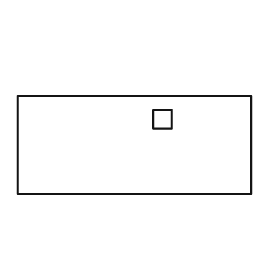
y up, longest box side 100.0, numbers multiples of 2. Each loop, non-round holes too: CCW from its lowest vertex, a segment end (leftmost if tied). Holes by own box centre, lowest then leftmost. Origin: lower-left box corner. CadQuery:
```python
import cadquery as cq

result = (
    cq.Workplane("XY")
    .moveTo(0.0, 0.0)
    .lineTo(100.0, 0.0)
    .lineTo(100.0, 42.0)
    .lineTo(0.0, 42.0)
    .close()
    .moveTo(58.0, 28.0)
    .lineTo(66.0, 28.0)
    .lineTo(66.0, 36.0)
    .lineTo(58.0, 36.0)
    .close()
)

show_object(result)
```